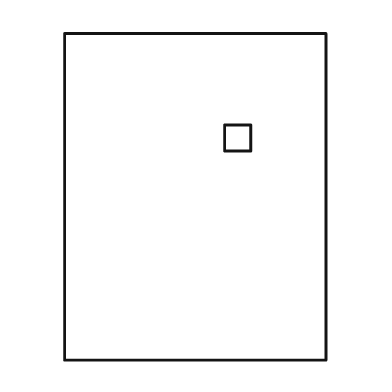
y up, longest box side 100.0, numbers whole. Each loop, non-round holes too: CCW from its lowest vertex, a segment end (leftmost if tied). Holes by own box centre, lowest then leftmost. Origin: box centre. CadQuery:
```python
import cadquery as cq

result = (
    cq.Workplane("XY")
    .moveTo(-40.0, -50.0)
    .lineTo(40.0, -50.0)
    .lineTo(40.0, 50.0)
    .lineTo(-40.0, 50.0)
    .close()
    .moveTo(9.0, 14.0)
    .lineTo(17.0, 14.0)
    .lineTo(17.0, 22.0)
    .lineTo(9.0, 22.0)
    .close()
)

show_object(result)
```